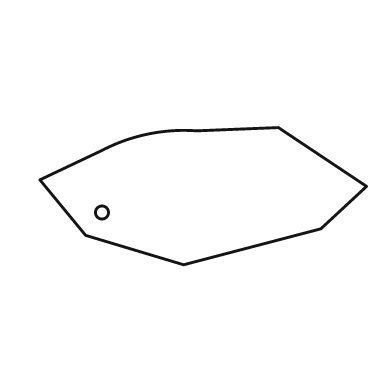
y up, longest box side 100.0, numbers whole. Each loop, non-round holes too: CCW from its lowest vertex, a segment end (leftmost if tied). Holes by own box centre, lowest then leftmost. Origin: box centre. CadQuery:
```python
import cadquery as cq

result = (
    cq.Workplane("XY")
    .moveTo(-6.0, -21.0)
    .lineTo(36.0, -10.0)
    .lineTo(50.0, 3.0)
    .lineTo(23.0, 21.0)
    .lineTo(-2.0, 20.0)
    .threePointArc((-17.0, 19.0), (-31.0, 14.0))
    .lineTo(-50.0, 5.0)
    .lineTo(-36.0, -12.0)
    .close()
    .moveTo(-31.0, -5.0)
    .circle(2.0)
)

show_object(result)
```